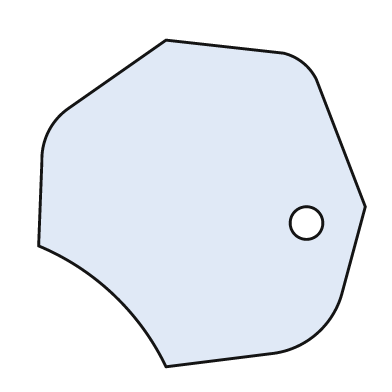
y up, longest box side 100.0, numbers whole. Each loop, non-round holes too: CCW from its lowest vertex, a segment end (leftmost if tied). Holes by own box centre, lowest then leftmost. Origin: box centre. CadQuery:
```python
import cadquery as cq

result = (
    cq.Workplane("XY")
    .moveTo(-11.0, -50.0)
    .lineTo(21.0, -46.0)
    .threePointArc((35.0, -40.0), (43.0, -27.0))
    .lineTo(50.0, -1.0)
    .lineTo(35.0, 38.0)
    .threePointArc((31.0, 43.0), (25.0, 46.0))
    .lineTo(-11.0, 50.0)
    .lineTo(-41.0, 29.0)
    .threePointArc((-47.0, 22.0), (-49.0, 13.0))
    .lineTo(-50.0, -13.0)
    .threePointArc((-27.0, -28.0), (-11.0, -50.0))
    .close()
    .moveTo(32.0, -6.0)
    .circle(5.0)
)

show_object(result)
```